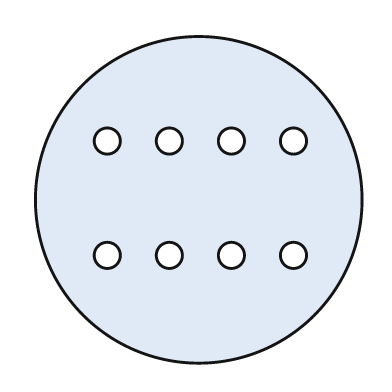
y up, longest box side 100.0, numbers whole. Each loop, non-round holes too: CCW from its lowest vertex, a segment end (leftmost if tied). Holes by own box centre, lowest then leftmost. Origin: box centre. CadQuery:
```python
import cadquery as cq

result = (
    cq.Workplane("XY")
    .moveTo(0.0, 0.0)
    .circle(50.0)
    .moveTo(-28.0, -17.0)
    .circle(4.0)
    .moveTo(-9.0, -17.0)
    .circle(4.0)
    .moveTo(10.0, -17.0)
    .circle(4.0)
    .moveTo(29.0, -17.0)
    .circle(4.0)
    .moveTo(-28.0, 18.0)
    .circle(4.0)
    .moveTo(-9.0, 18.0)
    .circle(4.0)
    .moveTo(10.0, 18.0)
    .circle(4.0)
    .moveTo(29.0, 18.0)
    .circle(4.0)
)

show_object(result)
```